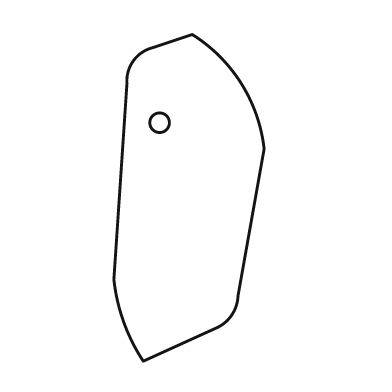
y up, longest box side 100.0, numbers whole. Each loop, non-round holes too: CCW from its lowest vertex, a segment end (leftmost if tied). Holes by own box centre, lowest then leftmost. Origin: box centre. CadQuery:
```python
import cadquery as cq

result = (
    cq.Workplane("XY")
    .moveTo(-14.0, -50.0)
    .lineTo(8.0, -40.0)
    .threePointArc((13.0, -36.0), (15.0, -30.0))
    .lineTo(23.0, 15.0)
    .threePointArc((16.0, 35.0), (1.0, 50.0))
    .lineTo(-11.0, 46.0)
    .threePointArc((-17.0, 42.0), (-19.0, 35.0))
    .lineTo(-23.0, -25.0)
    .threePointArc((-20.0, -38.0), (-14.0, -50.0))
    .close()
    .moveTo(-9.0, 23.0)
    .circle(3.0)
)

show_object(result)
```